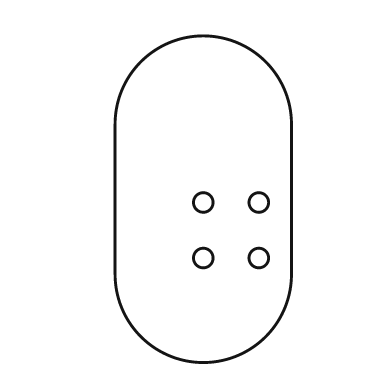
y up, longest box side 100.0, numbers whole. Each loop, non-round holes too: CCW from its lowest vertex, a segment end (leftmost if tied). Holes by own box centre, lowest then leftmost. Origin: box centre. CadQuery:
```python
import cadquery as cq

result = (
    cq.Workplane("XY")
    .moveTo(-27.0, -23.0)
    .threePointArc((0.0, -50.0), (27.0, -23.0))
    .lineTo(27.0, 23.0)
    .threePointArc((0.0, 50.0), (-27.0, 23.0))
    .close()
    .moveTo(0.0, -18.0)
    .circle(3.0)
    .moveTo(17.0, -18.0)
    .circle(3.0)
    .moveTo(0.0, -1.0)
    .circle(3.0)
    .moveTo(17.0, -1.0)
    .circle(3.0)
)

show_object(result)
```